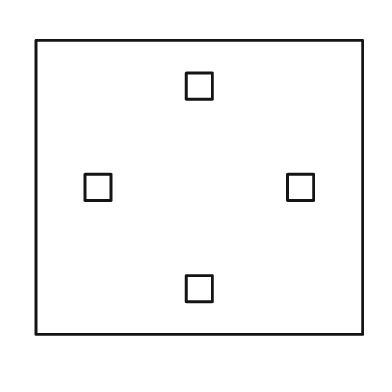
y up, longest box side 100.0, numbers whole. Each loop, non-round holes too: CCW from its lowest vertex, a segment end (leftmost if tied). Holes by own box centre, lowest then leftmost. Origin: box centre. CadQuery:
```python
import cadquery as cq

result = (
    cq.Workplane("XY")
    .moveTo(-50.0, -45.0)
    .lineTo(50.0, -45.0)
    .lineTo(50.0, 45.0)
    .lineTo(-50.0, 45.0)
    .close()
    .moveTo(-4.0, -35.0)
    .lineTo(4.0, -35.0)
    .lineTo(4.0, -27.0)
    .lineTo(-4.0, -27.0)
    .close()
    .moveTo(-35.0, -4.0)
    .lineTo(-27.0, -4.0)
    .lineTo(-27.0, 4.0)
    .lineTo(-35.0, 4.0)
    .close()
    .moveTo(27.0, -4.0)
    .lineTo(35.0, -4.0)
    .lineTo(35.0, 4.0)
    .lineTo(27.0, 4.0)
    .close()
    .moveTo(-4.0, 27.0)
    .lineTo(4.0, 27.0)
    .lineTo(4.0, 35.0)
    .lineTo(-4.0, 35.0)
    .close()
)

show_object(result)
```